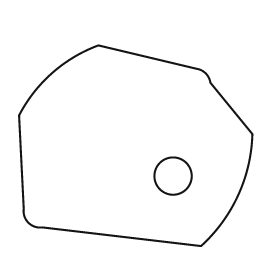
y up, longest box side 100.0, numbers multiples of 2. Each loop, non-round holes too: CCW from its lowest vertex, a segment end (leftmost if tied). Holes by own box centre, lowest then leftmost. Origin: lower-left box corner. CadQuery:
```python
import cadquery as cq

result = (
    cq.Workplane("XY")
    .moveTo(78.0, 0.0)
    .threePointArc((94.0, 22.0), (100.0, 48.0))
    .lineTo(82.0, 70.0)
    .threePointArc((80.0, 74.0), (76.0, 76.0))
    .lineTo(34.0, 86.0)
    .threePointArc((14.0, 74.0), (0.0, 56.0))
    .lineTo(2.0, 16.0)
    .threePointArc((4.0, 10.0), (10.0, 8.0))
    .close()
    .moveTo(66.0, 30.0)
    .circle(8.0)
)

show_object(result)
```